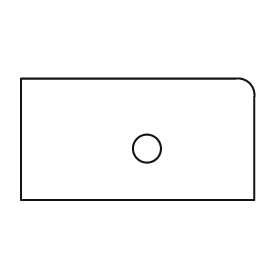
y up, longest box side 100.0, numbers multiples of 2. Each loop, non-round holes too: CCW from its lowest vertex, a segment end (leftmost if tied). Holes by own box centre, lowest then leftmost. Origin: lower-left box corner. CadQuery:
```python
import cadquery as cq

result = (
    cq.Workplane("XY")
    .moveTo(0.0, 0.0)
    .lineTo(100.0, 0.0)
    .lineTo(100.0, 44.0)
    .threePointArc((98.0, 50.0), (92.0, 52.0))
    .lineTo(0.0, 52.0)
    .close()
    .moveTo(54.0, 22.0)
    .circle(6.0)
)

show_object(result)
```